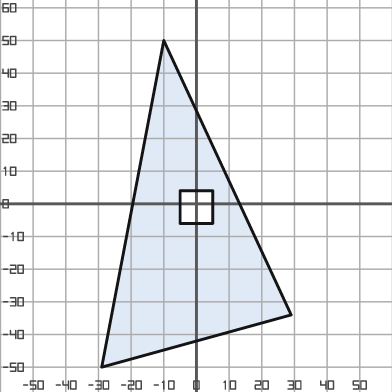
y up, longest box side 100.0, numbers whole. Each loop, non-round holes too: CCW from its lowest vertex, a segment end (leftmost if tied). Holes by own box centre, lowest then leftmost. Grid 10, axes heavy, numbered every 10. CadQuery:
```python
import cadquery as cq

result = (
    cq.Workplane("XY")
    .moveTo(-29.0, -50.0)
    .lineTo(29.0, -34.0)
    .lineTo(-10.0, 50.0)
    .close()
    .moveTo(-5.0, -6.0)
    .lineTo(5.0, -6.0)
    .lineTo(5.0, 4.0)
    .lineTo(-5.0, 4.0)
    .close()
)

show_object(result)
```